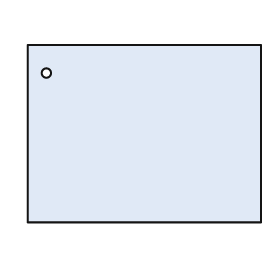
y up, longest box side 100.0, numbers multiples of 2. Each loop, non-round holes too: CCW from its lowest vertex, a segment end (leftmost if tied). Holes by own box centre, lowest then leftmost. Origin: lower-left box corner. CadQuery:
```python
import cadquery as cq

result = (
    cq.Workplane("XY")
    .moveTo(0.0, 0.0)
    .lineTo(100.0, 0.0)
    .lineTo(100.0, 76.0)
    .lineTo(0.0, 76.0)
    .close()
    .moveTo(8.0, 64.0)
    .circle(2.0)
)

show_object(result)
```